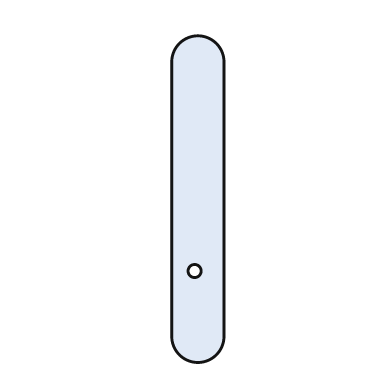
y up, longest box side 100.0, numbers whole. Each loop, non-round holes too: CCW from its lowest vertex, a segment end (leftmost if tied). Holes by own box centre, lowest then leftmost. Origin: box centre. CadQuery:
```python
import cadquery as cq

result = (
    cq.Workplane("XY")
    .moveTo(-8.0, -42.0)
    .threePointArc((0.0, -50.0), (8.0, -42.0))
    .lineTo(8.0, 42.0)
    .threePointArc((0.0, 50.0), (-8.0, 42.0))
    .close()
    .moveTo(-1.0, -22.0)
    .circle(2.0)
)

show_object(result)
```